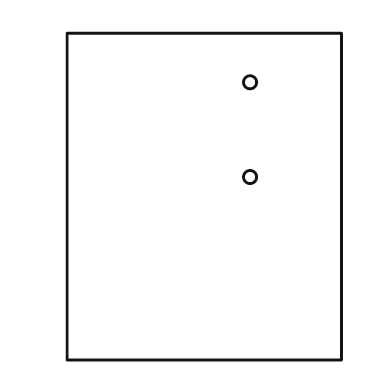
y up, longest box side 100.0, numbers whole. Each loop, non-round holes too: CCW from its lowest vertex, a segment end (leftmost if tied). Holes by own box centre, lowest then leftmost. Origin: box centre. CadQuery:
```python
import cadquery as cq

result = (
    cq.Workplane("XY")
    .moveTo(-42.0, -50.0)
    .lineTo(42.0, -50.0)
    .lineTo(42.0, 50.0)
    .lineTo(-42.0, 50.0)
    .close()
    .moveTo(14.0, 6.0)
    .circle(2.0)
    .moveTo(14.0, 35.0)
    .circle(2.0)
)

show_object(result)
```